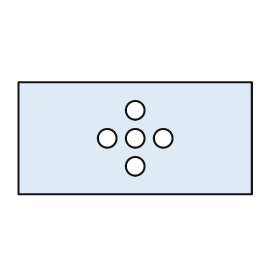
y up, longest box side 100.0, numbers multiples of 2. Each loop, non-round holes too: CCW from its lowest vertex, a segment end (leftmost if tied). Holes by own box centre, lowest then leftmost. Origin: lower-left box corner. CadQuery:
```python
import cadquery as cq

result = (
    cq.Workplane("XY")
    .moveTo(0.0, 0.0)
    .lineTo(100.0, 0.0)
    .lineTo(100.0, 48.0)
    .lineTo(0.0, 48.0)
    .close()
    .moveTo(50.0, 12.0)
    .circle(4.0)
    .moveTo(38.0, 24.0)
    .circle(4.0)
    .moveTo(50.0, 24.0)
    .circle(4.0)
    .moveTo(62.0, 24.0)
    .circle(4.0)
    .moveTo(50.0, 36.0)
    .circle(4.0)
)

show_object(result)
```